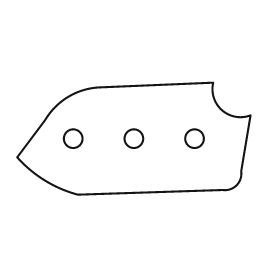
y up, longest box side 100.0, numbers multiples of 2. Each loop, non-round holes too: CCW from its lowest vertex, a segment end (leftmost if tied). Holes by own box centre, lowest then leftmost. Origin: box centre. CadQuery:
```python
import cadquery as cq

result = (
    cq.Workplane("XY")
    .moveTo(-24.0, -24.0)
    .lineTo(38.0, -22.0)
    .threePointArc((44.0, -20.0), (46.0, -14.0))
    .lineTo(50.0, 10.0)
    .threePointArc((38.0, 12.0), (34.0, 24.0))
    .lineTo(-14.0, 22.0)
    .threePointArc((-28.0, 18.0), (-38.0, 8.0))
    .lineTo(-50.0, -8.0)
    .threePointArc((-38.0, -18.0), (-24.0, -24.0))
    .close()
    .moveTo(-26.0, 0.0)
    .circle(4.0)
    .moveTo(0.0, 0.0)
    .circle(4.0)
    .moveTo(26.0, 0.0)
    .circle(4.0)
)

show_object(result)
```